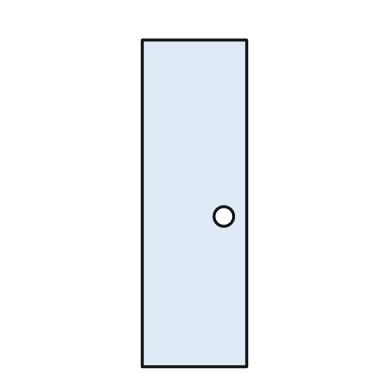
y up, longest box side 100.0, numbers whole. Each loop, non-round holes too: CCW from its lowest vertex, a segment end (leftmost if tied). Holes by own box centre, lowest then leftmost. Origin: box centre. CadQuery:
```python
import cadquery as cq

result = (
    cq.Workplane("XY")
    .moveTo(-16.0, -50.0)
    .lineTo(16.0, -50.0)
    .lineTo(16.0, 50.0)
    .lineTo(-16.0, 50.0)
    .close()
    .moveTo(9.0, -4.0)
    .circle(3.0)
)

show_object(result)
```